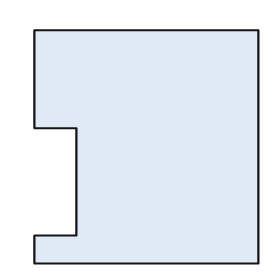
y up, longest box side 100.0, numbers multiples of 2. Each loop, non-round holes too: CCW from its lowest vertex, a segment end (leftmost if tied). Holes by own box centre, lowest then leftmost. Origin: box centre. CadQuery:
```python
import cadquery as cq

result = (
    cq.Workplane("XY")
    .moveTo(-48.0, -50.0)
    .lineTo(48.0, -50.0)
    .lineTo(48.0, 50.0)
    .lineTo(-48.0, 50.0)
    .lineTo(-48.0, 8.0)
    .lineTo(-30.0, 8.0)
    .lineTo(-30.0, -38.0)
    .lineTo(-48.0, -38.0)
    .close()
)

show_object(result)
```